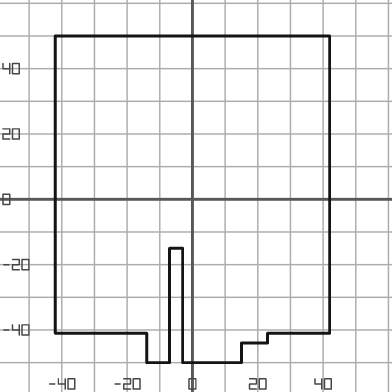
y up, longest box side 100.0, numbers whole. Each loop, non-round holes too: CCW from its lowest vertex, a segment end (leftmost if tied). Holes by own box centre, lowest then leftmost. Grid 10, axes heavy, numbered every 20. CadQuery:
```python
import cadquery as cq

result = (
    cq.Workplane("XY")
    .moveTo(-14.0, -50.0)
    .lineTo(-7.0, -50.0)
    .lineTo(-7.0, -15.0)
    .lineTo(-3.0, -15.0)
    .lineTo(-3.0, -50.0)
    .lineTo(15.0, -50.0)
    .lineTo(15.0, -44.0)
    .lineTo(23.0, -44.0)
    .lineTo(23.0, -41.0)
    .lineTo(42.0, -41.0)
    .lineTo(42.0, 50.0)
    .lineTo(-42.0, 50.0)
    .lineTo(-42.0, -41.0)
    .lineTo(-14.0, -41.0)
    .close()
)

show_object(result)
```